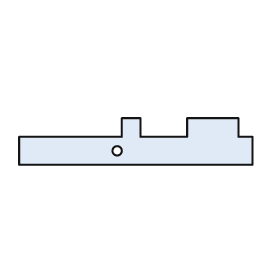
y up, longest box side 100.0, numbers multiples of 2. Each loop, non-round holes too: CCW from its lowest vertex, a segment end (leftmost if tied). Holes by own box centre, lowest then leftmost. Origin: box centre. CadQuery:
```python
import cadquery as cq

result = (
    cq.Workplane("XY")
    .moveTo(-50.0, -10.0)
    .lineTo(50.0, -10.0)
    .lineTo(50.0, 2.0)
    .lineTo(44.0, 2.0)
    .lineTo(44.0, 10.0)
    .lineTo(22.0, 10.0)
    .lineTo(22.0, 2.0)
    .lineTo(2.0, 2.0)
    .lineTo(2.0, 10.0)
    .lineTo(-6.0, 10.0)
    .lineTo(-6.0, 2.0)
    .lineTo(-50.0, 2.0)
    .close()
    .moveTo(-8.0, -4.0)
    .circle(2.0)
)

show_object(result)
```